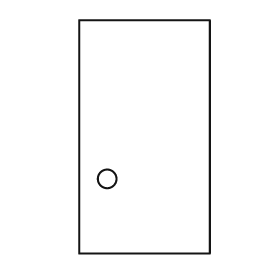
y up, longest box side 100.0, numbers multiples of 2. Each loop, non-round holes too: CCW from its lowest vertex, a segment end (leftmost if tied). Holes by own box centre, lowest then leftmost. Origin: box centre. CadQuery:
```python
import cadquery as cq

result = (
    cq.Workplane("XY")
    .moveTo(-28.0, -50.0)
    .lineTo(28.0, -50.0)
    .lineTo(28.0, 50.0)
    .lineTo(-28.0, 50.0)
    .close()
    .moveTo(-16.0, -18.0)
    .circle(4.0)
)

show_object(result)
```